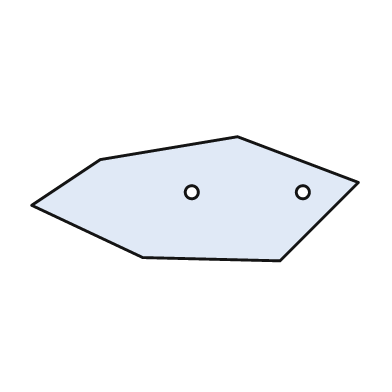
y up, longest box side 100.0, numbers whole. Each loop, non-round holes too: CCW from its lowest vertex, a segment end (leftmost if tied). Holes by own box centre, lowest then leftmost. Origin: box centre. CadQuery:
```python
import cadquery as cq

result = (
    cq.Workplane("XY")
    .moveTo(26.0, -19.0)
    .lineTo(50.0, 5.0)
    .lineTo(13.0, 19.0)
    .lineTo(-29.0, 12.0)
    .lineTo(-50.0, -2.0)
    .lineTo(-16.0, -18.0)
    .close()
    .moveTo(-1.0, 2.0)
    .circle(2.0)
    .moveTo(33.0, 2.0)
    .circle(2.0)
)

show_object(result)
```